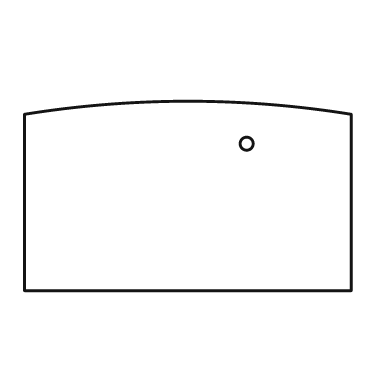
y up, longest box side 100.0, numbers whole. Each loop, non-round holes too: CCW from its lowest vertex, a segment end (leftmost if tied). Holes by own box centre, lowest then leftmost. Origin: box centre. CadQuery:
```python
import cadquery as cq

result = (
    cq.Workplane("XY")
    .moveTo(-50.0, -29.0)
    .lineTo(50.0, -29.0)
    .lineTo(50.0, 25.0)
    .threePointArc((0.0, 29.0), (-50.0, 25.0))
    .close()
    .moveTo(18.0, 16.0)
    .circle(2.0)
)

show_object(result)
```